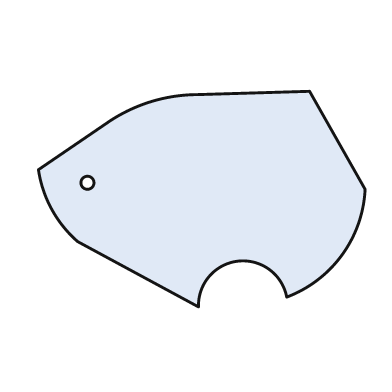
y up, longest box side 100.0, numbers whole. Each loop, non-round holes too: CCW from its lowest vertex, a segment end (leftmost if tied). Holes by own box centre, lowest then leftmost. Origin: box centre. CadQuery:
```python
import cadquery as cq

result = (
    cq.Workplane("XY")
    .moveTo(-1.0, -33.0)
    .threePointArc((11.0, -19.0), (26.0, -30.0))
    .threePointArc((43.0, -17.0), (50.0, 3.0))
    .lineTo(33.0, 33.0)
    .lineTo(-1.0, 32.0)
    .threePointArc((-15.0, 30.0), (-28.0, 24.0))
    .lineTo(-50.0, 9.0)
    .threePointArc((-46.0, -3.0), (-38.0, -13.0))
    .close()
    .moveTo(-35.0, 5.0)
    .circle(2.0)
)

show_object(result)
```